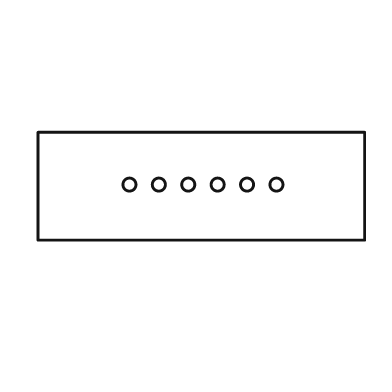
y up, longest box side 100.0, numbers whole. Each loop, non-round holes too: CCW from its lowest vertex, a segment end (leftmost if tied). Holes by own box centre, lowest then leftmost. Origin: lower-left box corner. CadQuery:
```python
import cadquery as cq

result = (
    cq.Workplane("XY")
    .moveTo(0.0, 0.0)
    .lineTo(100.0, 0.0)
    .lineTo(100.0, 33.0)
    .lineTo(0.0, 33.0)
    .close()
    .moveTo(28.0, 17.0)
    .circle(2.0)
    .moveTo(37.0, 17.0)
    .circle(2.0)
    .moveTo(46.0, 17.0)
    .circle(2.0)
    .moveTo(55.0, 17.0)
    .circle(2.0)
    .moveTo(64.0, 17.0)
    .circle(2.0)
    .moveTo(73.0, 17.0)
    .circle(2.0)
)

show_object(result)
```